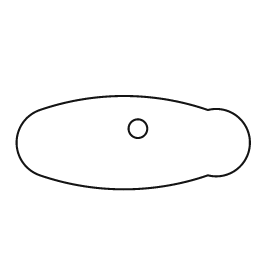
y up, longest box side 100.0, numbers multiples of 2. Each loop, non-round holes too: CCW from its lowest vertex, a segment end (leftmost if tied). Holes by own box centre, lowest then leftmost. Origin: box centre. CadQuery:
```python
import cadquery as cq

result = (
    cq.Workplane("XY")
    .moveTo(-40.0, -14.0)
    .threePointArc((-4.0, -20.0), (32.0, -14.0))
    .threePointArc((50.0, 0.0), (32.0, 14.0))
    .threePointArc((-4.0, 20.0), (-40.0, 14.0))
    .threePointArc((-50.0, 0.0), (-40.0, -14.0))
    .close()
    .moveTo(2.0, 6.0)
    .circle(4.0)
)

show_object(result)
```